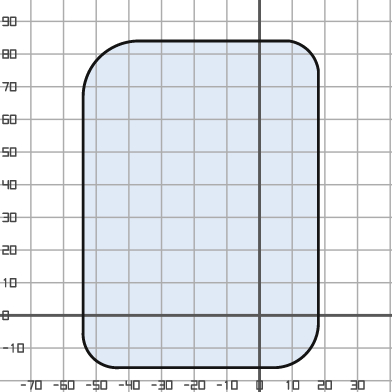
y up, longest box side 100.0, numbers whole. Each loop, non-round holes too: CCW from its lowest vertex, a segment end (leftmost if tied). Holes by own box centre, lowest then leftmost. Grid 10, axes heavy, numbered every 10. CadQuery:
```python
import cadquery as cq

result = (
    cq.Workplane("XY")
    .moveTo(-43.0, -16.0)
    .lineTo(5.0, -16.0)
    .threePointArc((14.0, -12.0), (18.0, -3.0))
    .lineTo(18.0, 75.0)
    .threePointArc((15.0, 81.0), (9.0, 84.0))
    .lineTo(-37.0, 84.0)
    .threePointArc((-49.0, 79.0), (-54.0, 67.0))
    .lineTo(-54.0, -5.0)
    .threePointArc((-51.0, -13.0), (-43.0, -16.0))
    .close()
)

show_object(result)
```